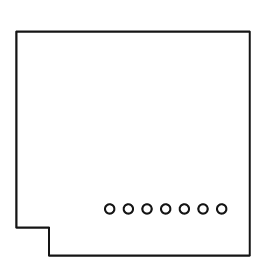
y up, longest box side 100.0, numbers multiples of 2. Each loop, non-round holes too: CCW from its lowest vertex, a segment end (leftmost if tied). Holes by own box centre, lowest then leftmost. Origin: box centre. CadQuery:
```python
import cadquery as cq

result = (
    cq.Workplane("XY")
    .moveTo(-36.0, -48.0)
    .lineTo(50.0, -48.0)
    .lineTo(50.0, 48.0)
    .lineTo(-50.0, 48.0)
    .lineTo(-50.0, -36.0)
    .lineTo(-36.0, -36.0)
    .close()
    .moveTo(-10.0, -28.0)
    .circle(2.0)
    .moveTo(-2.0, -28.0)
    .circle(2.0)
    .moveTo(6.0, -28.0)
    .circle(2.0)
    .moveTo(14.0, -28.0)
    .circle(2.0)
    .moveTo(22.0, -28.0)
    .circle(2.0)
    .moveTo(30.0, -28.0)
    .circle(2.0)
    .moveTo(38.0, -28.0)
    .circle(2.0)
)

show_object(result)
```